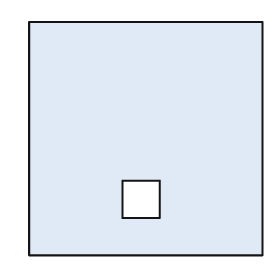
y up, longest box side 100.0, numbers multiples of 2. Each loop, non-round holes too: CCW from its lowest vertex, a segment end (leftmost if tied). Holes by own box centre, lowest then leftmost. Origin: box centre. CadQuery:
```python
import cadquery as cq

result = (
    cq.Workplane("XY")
    .moveTo(-50.0, -50.0)
    .lineTo(50.0, -50.0)
    .lineTo(50.0, 50.0)
    .lineTo(-50.0, 50.0)
    .close()
    .moveTo(-10.0, -34.0)
    .lineTo(6.0, -34.0)
    .lineTo(6.0, -18.0)
    .lineTo(-10.0, -18.0)
    .close()
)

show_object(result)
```